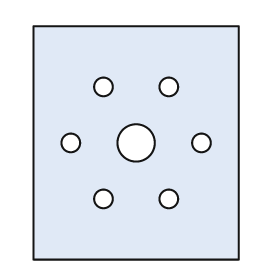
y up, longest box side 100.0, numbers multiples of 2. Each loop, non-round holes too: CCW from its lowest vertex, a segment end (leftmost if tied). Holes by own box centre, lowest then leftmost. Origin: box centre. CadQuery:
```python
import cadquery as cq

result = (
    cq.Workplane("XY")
    .moveTo(-44.0, -50.0)
    .lineTo(44.0, -50.0)
    .lineTo(44.0, 50.0)
    .lineTo(-44.0, 50.0)
    .close()
    .moveTo(-14.0, -24.0)
    .circle(4.0)
    .moveTo(14.0, -24.0)
    .circle(4.0)
    .moveTo(-28.0, 0.0)
    .circle(4.0)
    .moveTo(0.0, 0.0)
    .circle(8.0)
    .moveTo(28.0, 0.0)
    .circle(4.0)
    .moveTo(-14.0, 24.0)
    .circle(4.0)
    .moveTo(14.0, 24.0)
    .circle(4.0)
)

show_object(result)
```